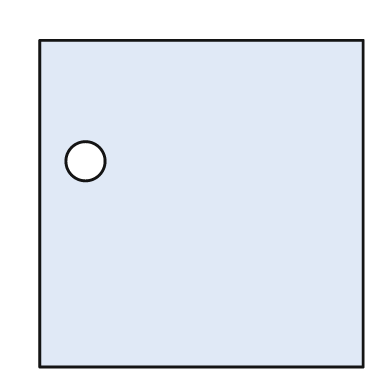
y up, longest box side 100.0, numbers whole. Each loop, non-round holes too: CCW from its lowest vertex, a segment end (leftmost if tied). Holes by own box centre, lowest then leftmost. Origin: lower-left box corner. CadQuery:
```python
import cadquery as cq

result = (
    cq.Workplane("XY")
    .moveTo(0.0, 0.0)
    .lineTo(99.0, 0.0)
    .lineTo(99.0, 100.0)
    .lineTo(0.0, 100.0)
    .close()
    .moveTo(14.0, 63.0)
    .circle(6.0)
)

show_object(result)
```